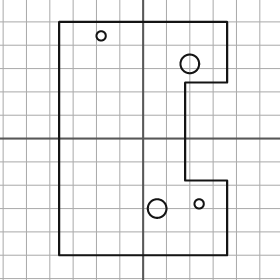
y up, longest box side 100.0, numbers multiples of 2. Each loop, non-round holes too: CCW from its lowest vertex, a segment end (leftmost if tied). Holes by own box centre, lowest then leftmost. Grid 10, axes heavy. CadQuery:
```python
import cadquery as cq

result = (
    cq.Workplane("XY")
    .moveTo(-36.0, -50.0)
    .lineTo(36.0, -50.0)
    .lineTo(36.0, -18.0)
    .lineTo(18.0, -18.0)
    .lineTo(18.0, 24.0)
    .lineTo(36.0, 24.0)
    .lineTo(36.0, 50.0)
    .lineTo(-36.0, 50.0)
    .close()
    .moveTo(6.0, -30.0)
    .circle(4.0)
    .moveTo(24.0, -28.0)
    .circle(2.0)
    .moveTo(20.0, 32.0)
    .circle(4.0)
    .moveTo(-18.0, 44.0)
    .circle(2.0)
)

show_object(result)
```